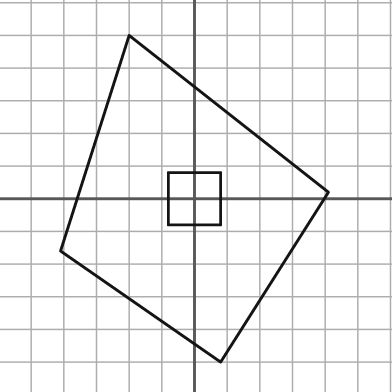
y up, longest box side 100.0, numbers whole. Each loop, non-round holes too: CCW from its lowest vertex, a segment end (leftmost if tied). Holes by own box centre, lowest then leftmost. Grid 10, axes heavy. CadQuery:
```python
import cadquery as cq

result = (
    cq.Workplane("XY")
    .moveTo(8.0, -50.0)
    .lineTo(41.0, 2.0)
    .lineTo(-20.0, 50.0)
    .lineTo(-41.0, -16.0)
    .close()
    .moveTo(-8.0, -8.0)
    .lineTo(8.0, -8.0)
    .lineTo(8.0, 8.0)
    .lineTo(-8.0, 8.0)
    .close()
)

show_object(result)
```